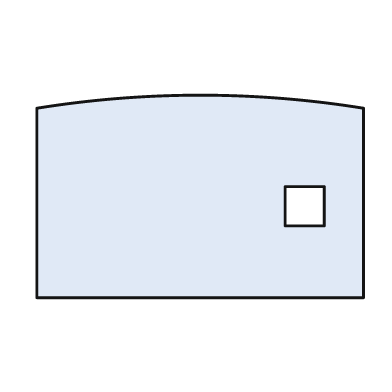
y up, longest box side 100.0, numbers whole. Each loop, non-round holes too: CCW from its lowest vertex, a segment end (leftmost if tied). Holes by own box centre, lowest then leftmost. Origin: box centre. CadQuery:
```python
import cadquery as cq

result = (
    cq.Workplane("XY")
    .moveTo(-50.0, -31.0)
    .lineTo(50.0, -31.0)
    .lineTo(50.0, 27.0)
    .threePointArc((0.0, 31.0), (-50.0, 27.0))
    .close()
    .moveTo(26.0, -9.0)
    .lineTo(38.0, -9.0)
    .lineTo(38.0, 3.0)
    .lineTo(26.0, 3.0)
    .close()
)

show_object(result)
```